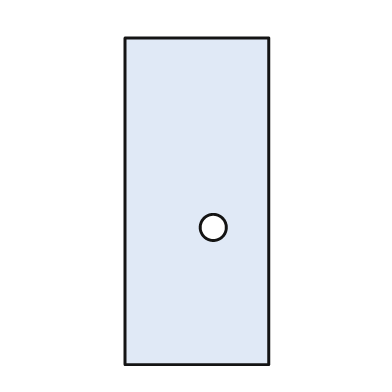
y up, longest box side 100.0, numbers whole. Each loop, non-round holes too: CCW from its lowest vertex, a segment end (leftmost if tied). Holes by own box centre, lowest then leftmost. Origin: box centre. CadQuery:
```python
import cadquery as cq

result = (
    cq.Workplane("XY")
    .moveTo(-22.0, -50.0)
    .lineTo(22.0, -50.0)
    .lineTo(22.0, 50.0)
    .lineTo(-22.0, 50.0)
    .close()
    .moveTo(5.0, -8.0)
    .circle(4.0)
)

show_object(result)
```